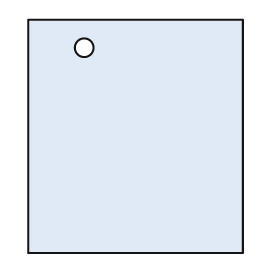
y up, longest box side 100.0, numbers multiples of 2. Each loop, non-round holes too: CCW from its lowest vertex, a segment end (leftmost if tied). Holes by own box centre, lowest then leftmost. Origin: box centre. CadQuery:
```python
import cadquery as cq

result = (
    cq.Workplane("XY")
    .moveTo(-46.0, -50.0)
    .lineTo(46.0, -50.0)
    .lineTo(46.0, 50.0)
    .lineTo(-46.0, 50.0)
    .close()
    .moveTo(-22.0, 38.0)
    .circle(4.0)
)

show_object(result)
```